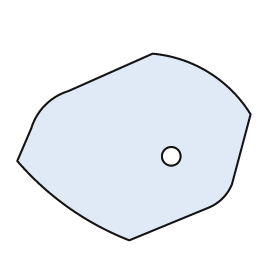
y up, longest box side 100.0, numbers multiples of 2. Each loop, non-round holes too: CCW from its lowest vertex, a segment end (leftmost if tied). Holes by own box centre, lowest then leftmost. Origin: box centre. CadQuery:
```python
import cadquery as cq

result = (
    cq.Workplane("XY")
    .moveTo(-2.0, -40.0)
    .lineTo(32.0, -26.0)
    .threePointArc((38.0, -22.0), (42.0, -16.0))
    .lineTo(50.0, 14.0)
    .threePointArc((32.0, 32.0), (8.0, 40.0))
    .lineTo(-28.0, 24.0)
    .threePointArc((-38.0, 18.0), (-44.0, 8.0))
    .lineTo(-50.0, -6.0)
    .threePointArc((-28.0, -26.0), (-2.0, -40.0))
    .close()
    .moveTo(16.0, -4.0)
    .circle(4.0)
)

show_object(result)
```